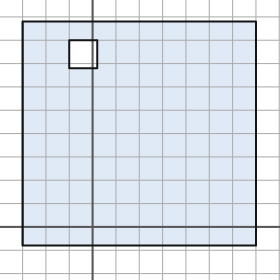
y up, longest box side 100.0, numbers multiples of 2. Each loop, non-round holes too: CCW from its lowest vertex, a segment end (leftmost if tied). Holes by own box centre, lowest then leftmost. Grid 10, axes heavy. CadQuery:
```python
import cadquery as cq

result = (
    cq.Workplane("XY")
    .moveTo(-30.0, -8.0)
    .lineTo(70.0, -8.0)
    .lineTo(70.0, 88.0)
    .lineTo(-30.0, 88.0)
    .close()
    .moveTo(-10.0, 68.0)
    .lineTo(2.0, 68.0)
    .lineTo(2.0, 80.0)
    .lineTo(-10.0, 80.0)
    .close()
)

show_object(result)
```